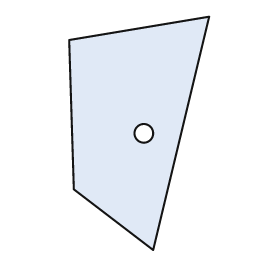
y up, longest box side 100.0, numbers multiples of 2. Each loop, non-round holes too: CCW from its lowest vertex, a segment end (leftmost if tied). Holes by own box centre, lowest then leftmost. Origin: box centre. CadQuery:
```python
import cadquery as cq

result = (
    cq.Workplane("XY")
    .moveTo(6.0, -50.0)
    .lineTo(30.0, 50.0)
    .lineTo(-30.0, 40.0)
    .lineTo(-28.0, -24.0)
    .close()
    .moveTo(2.0, 0.0)
    .circle(4.0)
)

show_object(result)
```